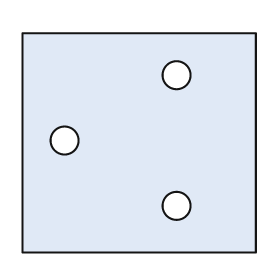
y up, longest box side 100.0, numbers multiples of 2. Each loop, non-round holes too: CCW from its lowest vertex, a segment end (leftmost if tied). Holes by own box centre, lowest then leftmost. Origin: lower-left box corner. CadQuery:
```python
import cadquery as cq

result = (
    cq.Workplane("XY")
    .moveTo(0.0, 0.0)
    .lineTo(100.0, 0.0)
    .lineTo(100.0, 94.0)
    .lineTo(0.0, 94.0)
    .close()
    .moveTo(66.0, 20.0)
    .circle(6.0)
    .moveTo(18.0, 48.0)
    .circle(6.0)
    .moveTo(66.0, 76.0)
    .circle(6.0)
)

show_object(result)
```